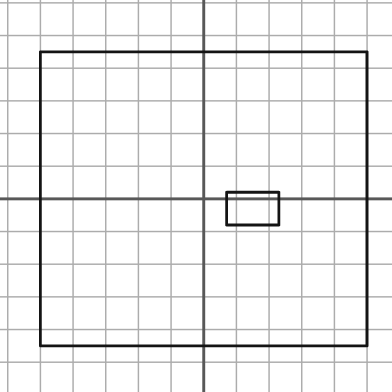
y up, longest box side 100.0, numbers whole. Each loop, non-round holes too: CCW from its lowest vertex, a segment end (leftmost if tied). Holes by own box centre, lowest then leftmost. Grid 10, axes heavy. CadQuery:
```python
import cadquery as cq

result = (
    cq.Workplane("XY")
    .moveTo(-50.0, -45.0)
    .lineTo(50.0, -45.0)
    .lineTo(50.0, 45.0)
    .lineTo(-50.0, 45.0)
    .close()
    .moveTo(7.0, -8.0)
    .lineTo(23.0, -8.0)
    .lineTo(23.0, 2.0)
    .lineTo(7.0, 2.0)
    .close()
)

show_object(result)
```